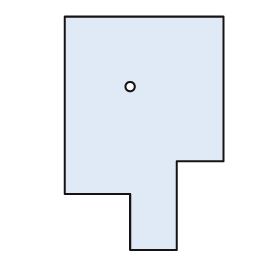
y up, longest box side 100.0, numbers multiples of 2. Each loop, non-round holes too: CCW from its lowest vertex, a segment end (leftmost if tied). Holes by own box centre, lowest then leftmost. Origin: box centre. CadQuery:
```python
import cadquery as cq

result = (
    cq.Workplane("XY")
    .moveTo(-6.0, -50.0)
    .lineTo(14.0, -50.0)
    .lineTo(14.0, -12.0)
    .lineTo(34.0, -12.0)
    .lineTo(34.0, 50.0)
    .lineTo(-34.0, 50.0)
    .lineTo(-34.0, -26.0)
    .lineTo(-6.0, -26.0)
    .close()
    .moveTo(-6.0, 20.0)
    .circle(2.0)
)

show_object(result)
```